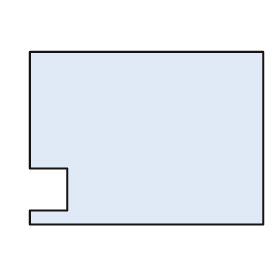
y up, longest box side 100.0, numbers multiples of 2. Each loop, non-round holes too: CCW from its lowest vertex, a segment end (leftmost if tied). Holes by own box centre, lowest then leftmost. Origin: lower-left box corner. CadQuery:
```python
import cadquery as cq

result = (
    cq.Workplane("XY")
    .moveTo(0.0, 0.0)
    .lineTo(100.0, 0.0)
    .lineTo(100.0, 74.0)
    .lineTo(0.0, 74.0)
    .lineTo(0.0, 24.0)
    .lineTo(16.0, 24.0)
    .lineTo(16.0, 6.0)
    .lineTo(0.0, 6.0)
    .close()
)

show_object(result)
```